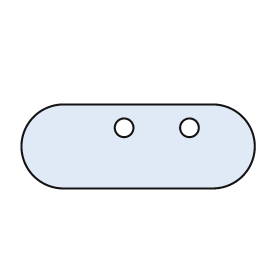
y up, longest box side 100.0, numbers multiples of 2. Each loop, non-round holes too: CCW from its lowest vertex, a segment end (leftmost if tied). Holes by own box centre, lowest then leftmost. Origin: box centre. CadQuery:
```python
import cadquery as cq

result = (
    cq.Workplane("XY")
    .moveTo(-32.0, -18.0)
    .lineTo(32.0, -18.0)
    .threePointArc((50.0, 0.0), (32.0, 18.0))
    .lineTo(-32.0, 18.0)
    .threePointArc((-50.0, 0.0), (-32.0, -18.0))
    .close()
    .moveTo(-6.0, 8.0)
    .circle(4.0)
    .moveTo(22.0, 8.0)
    .circle(4.0)
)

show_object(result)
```